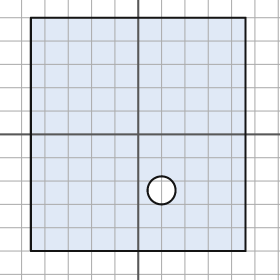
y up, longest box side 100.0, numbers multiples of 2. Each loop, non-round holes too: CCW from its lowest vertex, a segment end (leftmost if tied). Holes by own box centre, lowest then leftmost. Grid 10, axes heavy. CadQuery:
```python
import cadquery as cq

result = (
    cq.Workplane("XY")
    .moveTo(-46.0, -50.0)
    .lineTo(46.0, -50.0)
    .lineTo(46.0, 50.0)
    .lineTo(-46.0, 50.0)
    .close()
    .moveTo(10.0, -24.0)
    .circle(6.0)
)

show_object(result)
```